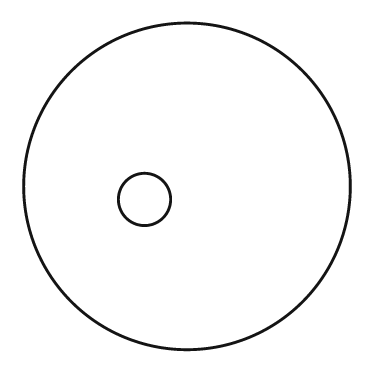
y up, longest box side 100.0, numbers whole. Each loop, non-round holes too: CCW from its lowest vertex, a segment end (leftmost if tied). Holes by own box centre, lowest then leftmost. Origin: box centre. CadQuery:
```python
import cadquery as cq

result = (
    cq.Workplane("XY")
    .moveTo(0.0, 0.0)
    .circle(50.0)
    .moveTo(-13.0, -4.0)
    .circle(8.0)
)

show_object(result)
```